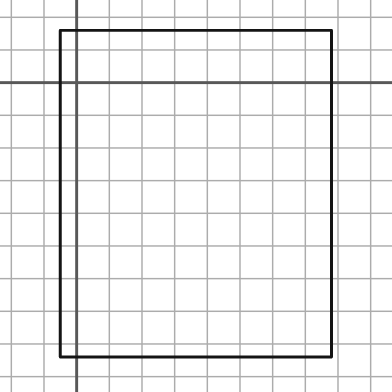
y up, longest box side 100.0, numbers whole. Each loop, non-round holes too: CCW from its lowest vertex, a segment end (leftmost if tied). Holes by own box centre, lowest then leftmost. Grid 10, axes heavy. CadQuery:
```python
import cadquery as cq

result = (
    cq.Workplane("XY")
    .moveTo(-5.0, -84.0)
    .lineTo(78.0, -84.0)
    .lineTo(78.0, 16.0)
    .lineTo(-5.0, 16.0)
    .close()
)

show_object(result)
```